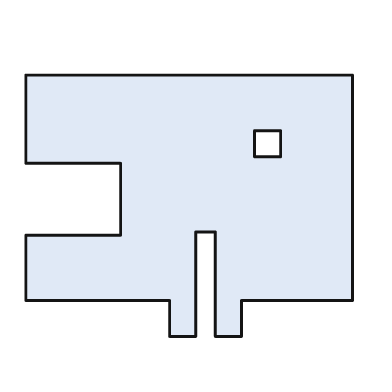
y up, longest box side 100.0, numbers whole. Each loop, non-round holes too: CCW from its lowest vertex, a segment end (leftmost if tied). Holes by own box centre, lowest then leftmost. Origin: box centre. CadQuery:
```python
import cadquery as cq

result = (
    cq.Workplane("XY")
    .moveTo(-6.0, -40.0)
    .lineTo(2.0, -40.0)
    .lineTo(2.0, -8.0)
    .lineTo(8.0, -8.0)
    .lineTo(8.0, -40.0)
    .lineTo(16.0, -40.0)
    .lineTo(16.0, -29.0)
    .lineTo(50.0, -29.0)
    .lineTo(50.0, 40.0)
    .lineTo(-50.0, 40.0)
    .lineTo(-50.0, 13.0)
    .lineTo(-21.0, 13.0)
    .lineTo(-21.0, -9.0)
    .lineTo(-50.0, -9.0)
    .lineTo(-50.0, -29.0)
    .lineTo(-6.0, -29.0)
    .close()
    .moveTo(20.0, 15.0)
    .lineTo(28.0, 15.0)
    .lineTo(28.0, 23.0)
    .lineTo(20.0, 23.0)
    .close()
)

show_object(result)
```